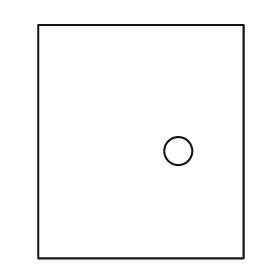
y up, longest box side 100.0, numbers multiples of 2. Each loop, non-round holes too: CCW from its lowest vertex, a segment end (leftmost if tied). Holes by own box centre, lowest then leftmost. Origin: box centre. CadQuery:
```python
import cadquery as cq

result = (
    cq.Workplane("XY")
    .moveTo(-44.0, -50.0)
    .lineTo(44.0, -50.0)
    .lineTo(44.0, 50.0)
    .lineTo(-44.0, 50.0)
    .close()
    .moveTo(16.0, -4.0)
    .circle(6.0)
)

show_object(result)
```